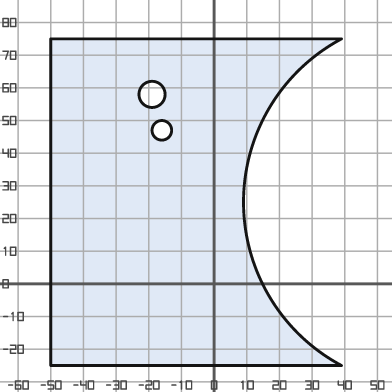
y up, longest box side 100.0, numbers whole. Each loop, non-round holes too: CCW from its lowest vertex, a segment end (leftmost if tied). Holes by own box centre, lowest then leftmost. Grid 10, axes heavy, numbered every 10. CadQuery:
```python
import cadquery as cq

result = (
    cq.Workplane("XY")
    .moveTo(-50.0, -25.0)
    .lineTo(39.0, -25.0)
    .threePointArc((9.0, 25.0), (39.0, 75.0))
    .lineTo(-50.0, 75.0)
    .close()
    .moveTo(-16.0, 47.0)
    .circle(3.0)
    .moveTo(-19.0, 58.0)
    .circle(4.0)
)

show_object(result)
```